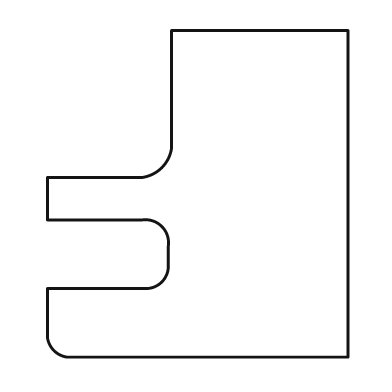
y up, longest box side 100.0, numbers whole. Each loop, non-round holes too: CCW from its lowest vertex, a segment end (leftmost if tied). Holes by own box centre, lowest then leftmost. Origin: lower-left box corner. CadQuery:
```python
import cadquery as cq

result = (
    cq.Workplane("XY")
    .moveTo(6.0, 0.0)
    .lineTo(92.0, 0.0)
    .lineTo(92.0, 100.0)
    .lineTo(38.0, 100.0)
    .lineTo(38.0, 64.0)
    .threePointArc((35.0, 58.0), (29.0, 55.0))
    .lineTo(0.0, 55.0)
    .lineTo(0.0, 42.0)
    .lineTo(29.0, 42.0)
    .threePointArc((35.0, 40.0), (37.0, 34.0))
    .lineTo(37.0, 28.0)
    .threePointArc((35.0, 23.0), (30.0, 21.0))
    .lineTo(0.0, 21.0)
    .lineTo(0.0, 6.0)
    .threePointArc((2.0, 2.0), (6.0, 0.0))
    .close()
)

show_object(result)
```